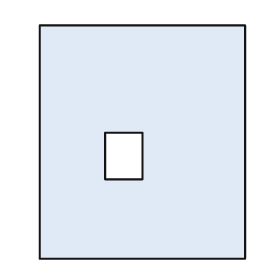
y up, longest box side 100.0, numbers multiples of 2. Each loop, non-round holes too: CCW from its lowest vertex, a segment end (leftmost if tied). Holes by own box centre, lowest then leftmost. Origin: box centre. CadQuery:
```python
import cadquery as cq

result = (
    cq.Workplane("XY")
    .moveTo(-44.0, -50.0)
    .lineTo(44.0, -50.0)
    .lineTo(44.0, 50.0)
    .lineTo(-44.0, 50.0)
    .close()
    .moveTo(-16.0, -16.0)
    .lineTo(0.0, -16.0)
    .lineTo(0.0, 4.0)
    .lineTo(-16.0, 4.0)
    .close()
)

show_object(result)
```